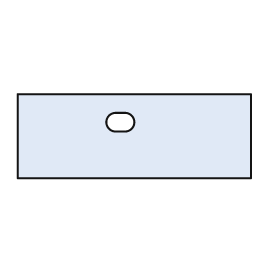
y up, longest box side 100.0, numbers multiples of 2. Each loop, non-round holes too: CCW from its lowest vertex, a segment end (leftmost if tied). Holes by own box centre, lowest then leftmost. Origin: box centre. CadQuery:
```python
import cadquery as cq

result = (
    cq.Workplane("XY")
    .moveTo(-50.0, -18.0)
    .lineTo(50.0, -18.0)
    .lineTo(50.0, 18.0)
    .lineTo(-50.0, 18.0)
    .close()
    .moveTo(-8.0, 2.0)
    .lineTo(-4.0, 2.0)
    .threePointArc((0.0, 6.0), (-4.0, 10.0))
    .lineTo(-8.0, 10.0)
    .threePointArc((-12.0, 6.0), (-8.0, 2.0))
    .close()
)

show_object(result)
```